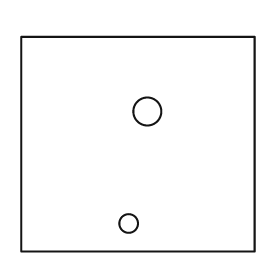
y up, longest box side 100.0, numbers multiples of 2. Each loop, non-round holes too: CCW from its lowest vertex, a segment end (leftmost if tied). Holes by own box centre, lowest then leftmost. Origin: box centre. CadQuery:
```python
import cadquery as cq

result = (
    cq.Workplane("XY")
    .moveTo(-50.0, -46.0)
    .lineTo(50.0, -46.0)
    .lineTo(50.0, 46.0)
    .lineTo(-50.0, 46.0)
    .close()
    .moveTo(-4.0, -34.0)
    .circle(4.0)
    .moveTo(4.0, 14.0)
    .circle(6.0)
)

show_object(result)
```